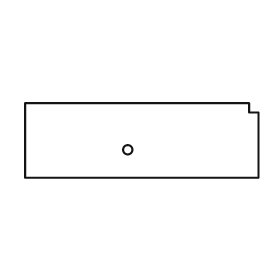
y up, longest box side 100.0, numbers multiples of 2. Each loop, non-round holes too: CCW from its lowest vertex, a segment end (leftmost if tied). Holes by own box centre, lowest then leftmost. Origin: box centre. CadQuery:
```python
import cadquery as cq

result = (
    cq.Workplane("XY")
    .moveTo(-50.0, -16.0)
    .lineTo(50.0, -16.0)
    .lineTo(50.0, 12.0)
    .lineTo(46.0, 12.0)
    .lineTo(46.0, 16.0)
    .lineTo(-50.0, 16.0)
    .close()
    .moveTo(-6.0, -4.0)
    .circle(2.0)
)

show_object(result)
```